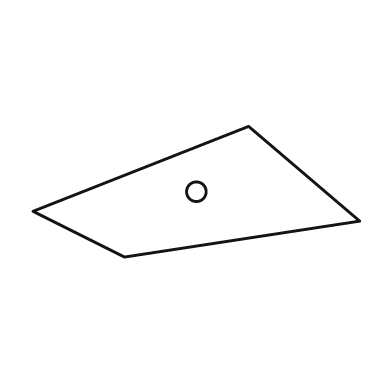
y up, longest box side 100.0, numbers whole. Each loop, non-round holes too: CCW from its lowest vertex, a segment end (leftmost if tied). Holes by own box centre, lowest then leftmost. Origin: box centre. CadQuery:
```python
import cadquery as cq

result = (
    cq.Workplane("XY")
    .moveTo(-22.0, -20.0)
    .lineTo(50.0, -9.0)
    .lineTo(16.0, 20.0)
    .lineTo(-50.0, -6.0)
    .close()
    .moveTo(0.0, 0.0)
    .circle(3.0)
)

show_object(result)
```